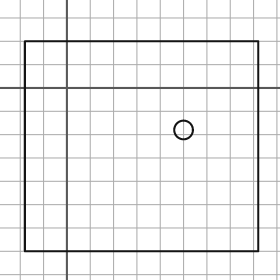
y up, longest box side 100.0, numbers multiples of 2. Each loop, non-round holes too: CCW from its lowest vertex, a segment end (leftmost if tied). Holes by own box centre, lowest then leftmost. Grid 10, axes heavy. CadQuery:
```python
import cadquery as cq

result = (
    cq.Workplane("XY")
    .moveTo(-18.0, -70.0)
    .lineTo(82.0, -70.0)
    .lineTo(82.0, 20.0)
    .lineTo(-18.0, 20.0)
    .close()
    .moveTo(50.0, -18.0)
    .circle(4.0)
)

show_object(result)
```